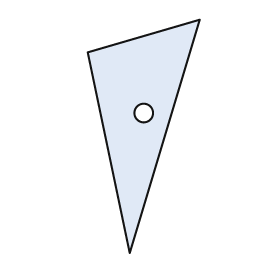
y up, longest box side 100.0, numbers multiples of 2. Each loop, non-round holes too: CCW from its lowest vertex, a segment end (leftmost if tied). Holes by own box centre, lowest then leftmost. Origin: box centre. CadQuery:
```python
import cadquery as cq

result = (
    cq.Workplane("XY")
    .moveTo(-6.0, -50.0)
    .lineTo(24.0, 50.0)
    .lineTo(-24.0, 36.0)
    .close()
    .moveTo(0.0, 10.0)
    .circle(4.0)
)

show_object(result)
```